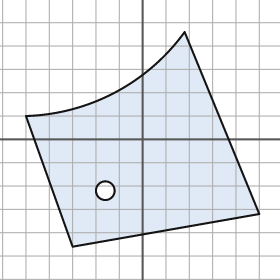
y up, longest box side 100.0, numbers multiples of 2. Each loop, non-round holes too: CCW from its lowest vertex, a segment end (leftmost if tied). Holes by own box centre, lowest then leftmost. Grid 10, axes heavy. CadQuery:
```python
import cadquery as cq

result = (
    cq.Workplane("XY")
    .moveTo(-30.0, -46.0)
    .lineTo(50.0, -32.0)
    .lineTo(18.0, 46.0)
    .threePointArc((-12.0, 20.0), (-50.0, 10.0))
    .close()
    .moveTo(-16.0, -22.0)
    .circle(4.0)
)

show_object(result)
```